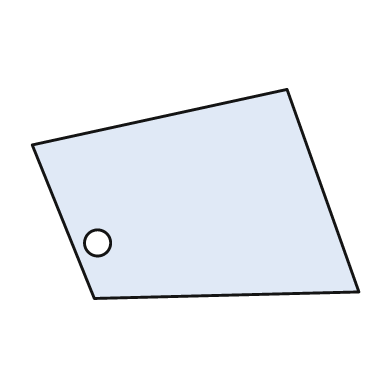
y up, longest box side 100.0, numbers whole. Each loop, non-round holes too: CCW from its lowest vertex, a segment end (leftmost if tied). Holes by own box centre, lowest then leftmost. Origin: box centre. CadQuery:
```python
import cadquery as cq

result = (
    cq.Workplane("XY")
    .moveTo(-31.0, -32.0)
    .lineTo(50.0, -30.0)
    .lineTo(28.0, 32.0)
    .lineTo(-50.0, 15.0)
    .close()
    .moveTo(-30.0, -15.0)
    .circle(4.0)
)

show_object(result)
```